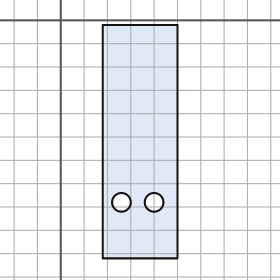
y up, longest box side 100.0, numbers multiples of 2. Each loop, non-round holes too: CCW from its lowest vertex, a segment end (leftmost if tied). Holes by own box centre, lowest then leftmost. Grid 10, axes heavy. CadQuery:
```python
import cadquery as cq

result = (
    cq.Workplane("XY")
    .moveTo(18.0, -102.0)
    .lineTo(50.0, -102.0)
    .lineTo(50.0, -2.0)
    .lineTo(18.0, -2.0)
    .close()
    .moveTo(26.0, -78.0)
    .circle(4.0)
    .moveTo(40.0, -78.0)
    .circle(4.0)
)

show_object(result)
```